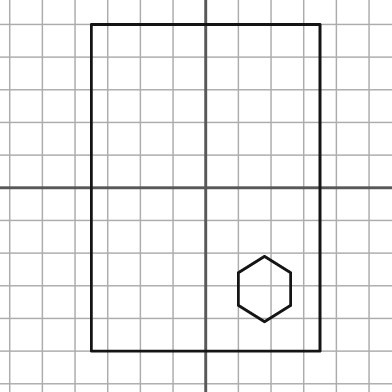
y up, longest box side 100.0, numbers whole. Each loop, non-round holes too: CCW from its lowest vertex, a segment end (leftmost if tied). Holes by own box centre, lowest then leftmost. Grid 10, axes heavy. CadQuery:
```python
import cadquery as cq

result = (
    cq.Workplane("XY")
    .moveTo(-35.0, -50.0)
    .lineTo(35.0, -50.0)
    .lineTo(35.0, 50.0)
    .lineTo(-35.0, 50.0)
    .close()
    .moveTo(18.0, -41.0)
    .lineTo(26.0, -36.0)
    .lineTo(26.0, -26.0)
    .lineTo(18.0, -21.0)
    .lineTo(10.0, -26.0)
    .lineTo(10.0, -36.0)
    .close()
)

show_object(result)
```